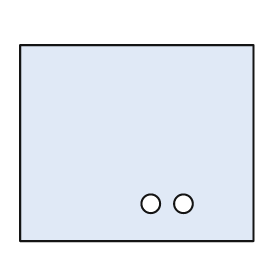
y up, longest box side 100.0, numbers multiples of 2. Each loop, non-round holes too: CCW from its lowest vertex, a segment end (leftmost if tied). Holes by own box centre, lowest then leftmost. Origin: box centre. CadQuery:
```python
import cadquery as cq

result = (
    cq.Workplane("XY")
    .moveTo(-50.0, -42.0)
    .lineTo(50.0, -42.0)
    .lineTo(50.0, 42.0)
    .lineTo(-50.0, 42.0)
    .close()
    .moveTo(6.0, -26.0)
    .circle(4.0)
    .moveTo(20.0, -26.0)
    .circle(4.0)
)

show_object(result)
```